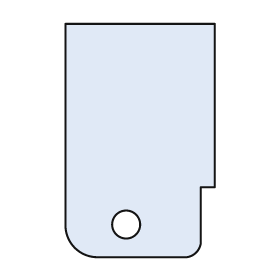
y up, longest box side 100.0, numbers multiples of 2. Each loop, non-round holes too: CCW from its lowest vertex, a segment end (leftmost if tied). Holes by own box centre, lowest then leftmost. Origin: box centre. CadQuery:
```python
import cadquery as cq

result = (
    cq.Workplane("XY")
    .moveTo(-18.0, -50.0)
    .lineTo(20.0, -50.0)
    .threePointArc((24.0, -48.0), (26.0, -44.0))
    .lineTo(26.0, -20.0)
    .lineTo(32.0, -20.0)
    .lineTo(32.0, 50.0)
    .lineTo(-32.0, 50.0)
    .lineTo(-32.0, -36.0)
    .threePointArc((-28.0, -46.0), (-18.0, -50.0))
    .close()
    .moveTo(-6.0, -36.0)
    .circle(6.0)
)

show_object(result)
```